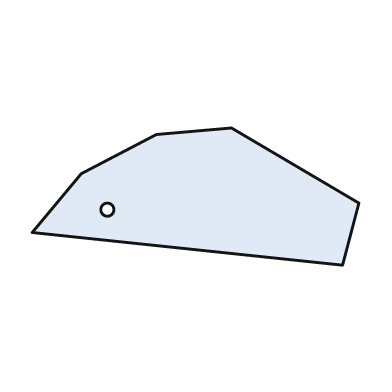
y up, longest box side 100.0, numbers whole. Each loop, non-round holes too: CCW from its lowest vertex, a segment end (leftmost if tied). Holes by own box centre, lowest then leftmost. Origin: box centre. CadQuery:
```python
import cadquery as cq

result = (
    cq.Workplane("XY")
    .moveTo(45.0, -21.0)
    .lineTo(50.0, -2.0)
    .lineTo(11.0, 21.0)
    .lineTo(-12.0, 19.0)
    .lineTo(-35.0, 7.0)
    .lineTo(-50.0, -11.0)
    .close()
    .moveTo(-27.0, -4.0)
    .circle(2.0)
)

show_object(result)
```